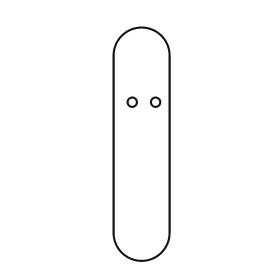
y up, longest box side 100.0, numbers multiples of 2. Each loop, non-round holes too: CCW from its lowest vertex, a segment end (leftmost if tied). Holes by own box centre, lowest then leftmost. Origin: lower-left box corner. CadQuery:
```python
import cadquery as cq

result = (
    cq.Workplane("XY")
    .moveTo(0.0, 12.0)
    .threePointArc((12.0, 0.0), (24.0, 12.0))
    .lineTo(24.0, 88.0)
    .threePointArc((12.0, 100.0), (0.0, 88.0))
    .close()
    .moveTo(8.0, 68.0)
    .circle(2.0)
    .moveTo(18.0, 68.0)
    .circle(2.0)
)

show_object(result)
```